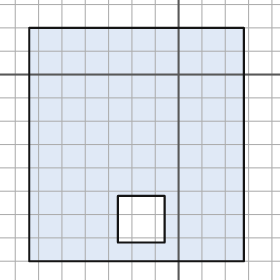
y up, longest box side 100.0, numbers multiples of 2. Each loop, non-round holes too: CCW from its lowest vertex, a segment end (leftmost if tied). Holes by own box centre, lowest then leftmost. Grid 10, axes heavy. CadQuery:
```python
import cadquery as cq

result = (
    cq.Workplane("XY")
    .moveTo(-64.0, -80.0)
    .lineTo(28.0, -80.0)
    .lineTo(28.0, 20.0)
    .lineTo(-64.0, 20.0)
    .close()
    .moveTo(-26.0, -72.0)
    .lineTo(-6.0, -72.0)
    .lineTo(-6.0, -52.0)
    .lineTo(-26.0, -52.0)
    .close()
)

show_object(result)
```